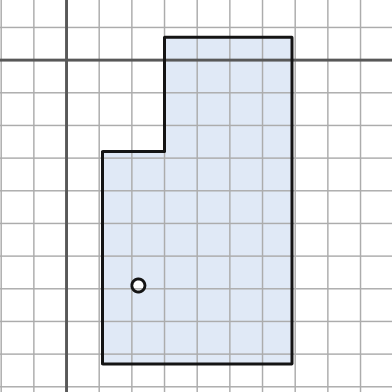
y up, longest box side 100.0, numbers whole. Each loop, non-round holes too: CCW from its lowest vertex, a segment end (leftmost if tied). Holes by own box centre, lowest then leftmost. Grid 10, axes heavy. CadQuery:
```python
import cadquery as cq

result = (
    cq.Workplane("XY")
    .moveTo(11.0, -93.0)
    .lineTo(69.0, -93.0)
    .lineTo(69.0, 7.0)
    .lineTo(30.0, 7.0)
    .lineTo(30.0, -28.0)
    .lineTo(11.0, -28.0)
    .close()
    .moveTo(22.0, -69.0)
    .circle(2.0)
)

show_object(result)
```